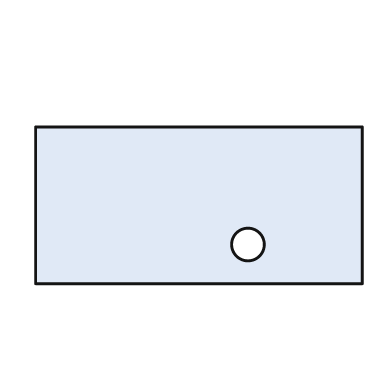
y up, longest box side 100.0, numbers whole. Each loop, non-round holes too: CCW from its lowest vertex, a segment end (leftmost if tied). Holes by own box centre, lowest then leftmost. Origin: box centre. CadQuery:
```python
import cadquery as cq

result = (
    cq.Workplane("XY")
    .moveTo(-50.0, -24.0)
    .lineTo(50.0, -24.0)
    .lineTo(50.0, 24.0)
    .lineTo(-50.0, 24.0)
    .close()
    .moveTo(15.0, -12.0)
    .circle(5.0)
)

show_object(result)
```